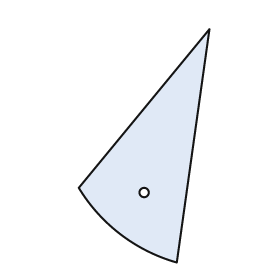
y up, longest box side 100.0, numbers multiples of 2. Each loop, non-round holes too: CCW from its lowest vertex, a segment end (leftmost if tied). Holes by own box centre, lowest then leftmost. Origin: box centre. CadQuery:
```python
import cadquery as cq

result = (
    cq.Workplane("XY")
    .moveTo(14.0, -50.0)
    .lineTo(28.0, 50.0)
    .lineTo(-28.0, -18.0)
    .threePointArc((-10.0, -38.0), (14.0, -50.0))
    .close()
    .moveTo(0.0, -20.0)
    .circle(2.0)
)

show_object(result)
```